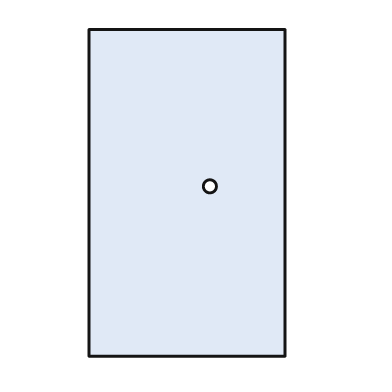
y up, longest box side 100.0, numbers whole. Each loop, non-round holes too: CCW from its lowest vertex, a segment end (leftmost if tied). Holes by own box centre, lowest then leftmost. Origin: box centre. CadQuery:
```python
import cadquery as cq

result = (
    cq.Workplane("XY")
    .moveTo(-30.0, -50.0)
    .lineTo(30.0, -50.0)
    .lineTo(30.0, 50.0)
    .lineTo(-30.0, 50.0)
    .close()
    .moveTo(7.0, 2.0)
    .circle(2.0)
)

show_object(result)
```